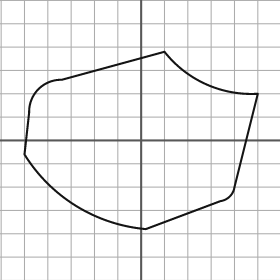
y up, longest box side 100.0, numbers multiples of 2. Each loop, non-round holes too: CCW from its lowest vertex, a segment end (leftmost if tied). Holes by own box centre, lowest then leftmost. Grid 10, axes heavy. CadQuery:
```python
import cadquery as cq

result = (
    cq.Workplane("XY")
    .moveTo(2.0, -38.0)
    .lineTo(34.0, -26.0)
    .threePointArc((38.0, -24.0), (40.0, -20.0))
    .lineTo(50.0, 20.0)
    .threePointArc((28.0, 24.0), (10.0, 38.0))
    .lineTo(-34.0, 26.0)
    .threePointArc((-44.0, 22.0), (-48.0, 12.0))
    .lineTo(-50.0, -6.0)
    .threePointArc((-28.0, -28.0), (2.0, -38.0))
    .close()
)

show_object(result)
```